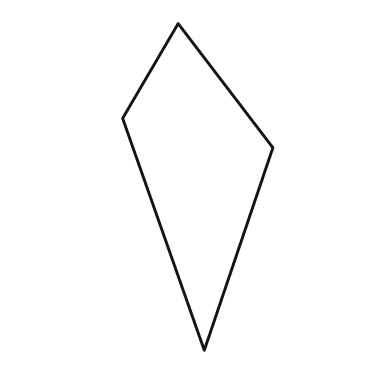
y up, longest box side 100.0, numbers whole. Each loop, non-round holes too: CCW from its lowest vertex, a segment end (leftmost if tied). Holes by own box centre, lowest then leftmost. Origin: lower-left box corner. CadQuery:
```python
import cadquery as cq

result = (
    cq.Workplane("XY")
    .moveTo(25.0, 0.0)
    .lineTo(46.0, 62.0)
    .lineTo(17.0, 100.0)
    .lineTo(0.0, 71.0)
    .close()
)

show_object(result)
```